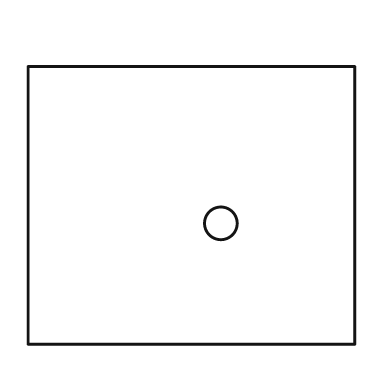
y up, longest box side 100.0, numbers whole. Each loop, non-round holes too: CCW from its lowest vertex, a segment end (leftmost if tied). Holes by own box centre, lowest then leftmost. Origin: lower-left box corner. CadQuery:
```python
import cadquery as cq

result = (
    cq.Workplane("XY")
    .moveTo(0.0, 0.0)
    .lineTo(100.0, 0.0)
    .lineTo(100.0, 85.0)
    .lineTo(0.0, 85.0)
    .close()
    .moveTo(59.0, 37.0)
    .circle(5.0)
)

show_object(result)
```